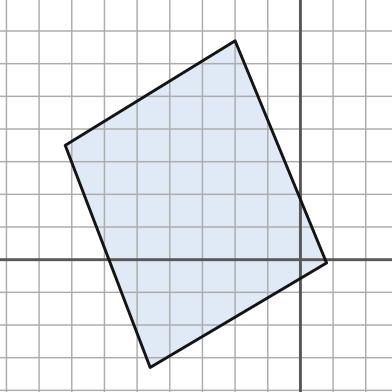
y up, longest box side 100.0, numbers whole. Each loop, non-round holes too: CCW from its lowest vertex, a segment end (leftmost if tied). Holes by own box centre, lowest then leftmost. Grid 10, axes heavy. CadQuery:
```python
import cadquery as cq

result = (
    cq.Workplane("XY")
    .moveTo(-46.0, -33.0)
    .lineTo(8.0, -1.0)
    .lineTo(-20.0, 67.0)
    .lineTo(-72.0, 35.0)
    .close()
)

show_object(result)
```